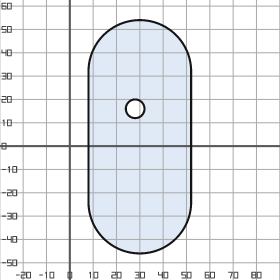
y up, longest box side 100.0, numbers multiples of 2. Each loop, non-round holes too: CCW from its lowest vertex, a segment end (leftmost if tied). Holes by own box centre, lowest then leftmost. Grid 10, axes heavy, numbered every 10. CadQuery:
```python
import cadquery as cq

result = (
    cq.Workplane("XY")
    .moveTo(8.0, -24.0)
    .threePointArc((30.0, -46.0), (52.0, -24.0))
    .lineTo(52.0, 32.0)
    .threePointArc((30.0, 54.0), (8.0, 32.0))
    .close()
    .moveTo(28.0, 16.0)
    .circle(4.0)
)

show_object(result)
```